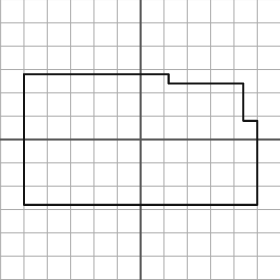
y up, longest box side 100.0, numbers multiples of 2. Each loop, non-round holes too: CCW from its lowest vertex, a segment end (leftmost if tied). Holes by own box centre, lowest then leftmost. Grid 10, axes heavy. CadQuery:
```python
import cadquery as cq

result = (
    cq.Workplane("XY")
    .moveTo(-50.0, -28.0)
    .lineTo(50.0, -28.0)
    .lineTo(50.0, 8.0)
    .lineTo(44.0, 8.0)
    .lineTo(44.0, 24.0)
    .lineTo(12.0, 24.0)
    .lineTo(12.0, 28.0)
    .lineTo(-50.0, 28.0)
    .close()
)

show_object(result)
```